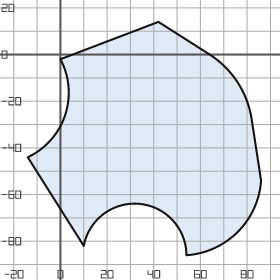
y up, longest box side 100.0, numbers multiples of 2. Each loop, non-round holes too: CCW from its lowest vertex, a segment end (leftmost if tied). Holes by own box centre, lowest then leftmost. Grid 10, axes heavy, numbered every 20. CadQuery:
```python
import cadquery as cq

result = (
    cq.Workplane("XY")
    .moveTo(54.0, -86.0)
    .threePointArc((76.0, -76.0), (86.0, -54.0))
    .lineTo(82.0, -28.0)
    .threePointArc((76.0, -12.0), (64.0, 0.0))
    .lineTo(42.0, 14.0)
    .lineTo(0.0, -2.0)
    .threePointArc((2.0, -26.0), (-14.0, -44.0))
    .lineTo(10.0, -82.0)
    .threePointArc((34.0, -64.0), (54.0, -86.0))
    .close()
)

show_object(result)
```